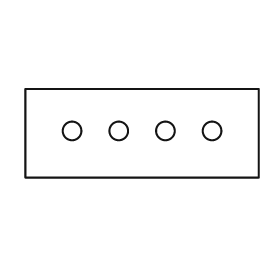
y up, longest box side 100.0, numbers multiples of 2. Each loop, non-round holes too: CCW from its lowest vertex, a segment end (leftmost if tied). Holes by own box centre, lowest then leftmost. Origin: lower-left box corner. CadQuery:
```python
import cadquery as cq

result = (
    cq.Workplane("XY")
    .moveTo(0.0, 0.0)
    .lineTo(100.0, 0.0)
    .lineTo(100.0, 38.0)
    .lineTo(0.0, 38.0)
    .close()
    .moveTo(20.0, 20.0)
    .circle(4.0)
    .moveTo(40.0, 20.0)
    .circle(4.0)
    .moveTo(60.0, 20.0)
    .circle(4.0)
    .moveTo(80.0, 20.0)
    .circle(4.0)
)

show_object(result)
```